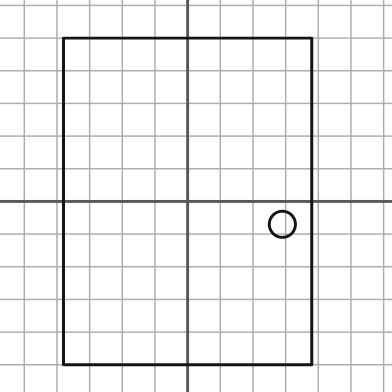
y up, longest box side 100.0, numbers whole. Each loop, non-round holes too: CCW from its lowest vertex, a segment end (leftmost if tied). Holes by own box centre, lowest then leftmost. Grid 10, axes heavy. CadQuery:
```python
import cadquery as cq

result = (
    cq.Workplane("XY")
    .moveTo(-38.0, -50.0)
    .lineTo(38.0, -50.0)
    .lineTo(38.0, 50.0)
    .lineTo(-38.0, 50.0)
    .close()
    .moveTo(29.0, -7.0)
    .circle(4.0)
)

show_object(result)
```